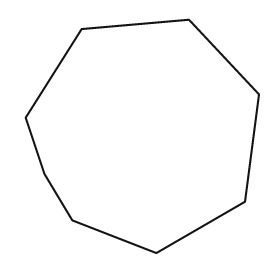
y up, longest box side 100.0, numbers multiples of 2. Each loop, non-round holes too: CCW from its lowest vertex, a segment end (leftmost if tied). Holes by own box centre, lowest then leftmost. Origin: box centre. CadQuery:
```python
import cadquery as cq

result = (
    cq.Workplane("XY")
    .moveTo(6.0, -50.0)
    .lineTo(44.0, -28.0)
    .lineTo(50.0, 18.0)
    .lineTo(20.0, 50.0)
    .lineTo(-26.0, 46.0)
    .lineTo(-50.0, 8.0)
    .lineTo(-42.0, -16.0)
    .lineTo(-30.0, -36.0)
    .close()
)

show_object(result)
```